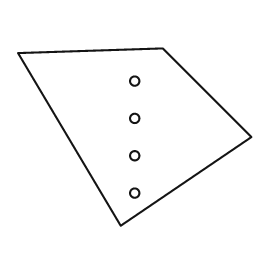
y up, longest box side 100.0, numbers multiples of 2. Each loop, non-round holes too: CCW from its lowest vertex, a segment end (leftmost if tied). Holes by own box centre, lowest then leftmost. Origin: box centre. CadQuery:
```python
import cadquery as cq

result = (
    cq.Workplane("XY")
    .moveTo(-6.0, -38.0)
    .lineTo(50.0, 0.0)
    .lineTo(12.0, 38.0)
    .lineTo(-50.0, 36.0)
    .close()
    .moveTo(0.0, -24.0)
    .circle(2.0)
    .moveTo(0.0, -8.0)
    .circle(2.0)
    .moveTo(0.0, 8.0)
    .circle(2.0)
    .moveTo(0.0, 24.0)
    .circle(2.0)
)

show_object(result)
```